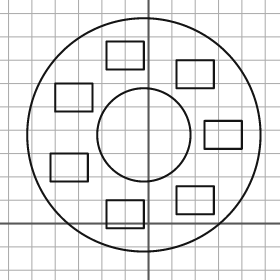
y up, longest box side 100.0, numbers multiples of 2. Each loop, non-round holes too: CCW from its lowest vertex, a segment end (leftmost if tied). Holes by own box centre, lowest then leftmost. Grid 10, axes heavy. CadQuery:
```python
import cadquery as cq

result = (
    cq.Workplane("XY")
    .moveTo(-2.0, 38.0)
    .circle(50.0)
    .moveTo(-18.0, -2.0)
    .lineTo(-2.0, -2.0)
    .lineTo(-2.0, 10.0)
    .lineTo(-18.0, 10.0)
    .close()
    .moveTo(12.0, 4.0)
    .lineTo(28.0, 4.0)
    .lineTo(28.0, 16.0)
    .lineTo(12.0, 16.0)
    .close()
    .moveTo(-42.0, 18.0)
    .lineTo(-26.0, 18.0)
    .lineTo(-26.0, 30.0)
    .lineTo(-42.0, 30.0)
    .close()
    .moveTo(-2.0, 38.0)
    .circle(20.0)
    .moveTo(24.0, 32.0)
    .lineTo(40.0, 32.0)
    .lineTo(40.0, 44.0)
    .lineTo(24.0, 44.0)
    .close()
    .moveTo(-40.0, 48.0)
    .lineTo(-24.0, 48.0)
    .lineTo(-24.0, 60.0)
    .lineTo(-40.0, 60.0)
    .close()
    .moveTo(12.0, 58.0)
    .lineTo(28.0, 58.0)
    .lineTo(28.0, 70.0)
    .lineTo(12.0, 70.0)
    .close()
    .moveTo(-18.0, 66.0)
    .lineTo(-2.0, 66.0)
    .lineTo(-2.0, 78.0)
    .lineTo(-18.0, 78.0)
    .close()
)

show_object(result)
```